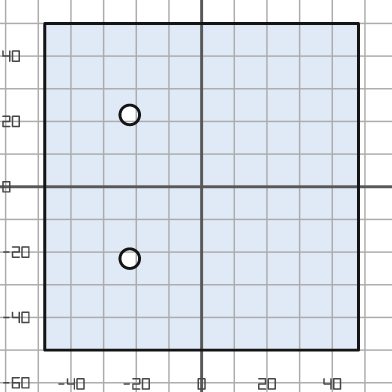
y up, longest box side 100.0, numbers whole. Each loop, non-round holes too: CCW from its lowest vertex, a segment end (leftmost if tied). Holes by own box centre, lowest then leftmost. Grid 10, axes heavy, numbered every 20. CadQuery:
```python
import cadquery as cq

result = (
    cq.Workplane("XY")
    .moveTo(-48.0, -50.0)
    .lineTo(48.0, -50.0)
    .lineTo(48.0, 50.0)
    .lineTo(-48.0, 50.0)
    .close()
    .moveTo(-22.0, -22.0)
    .circle(3.0)
    .moveTo(-22.0, 22.0)
    .circle(3.0)
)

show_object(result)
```